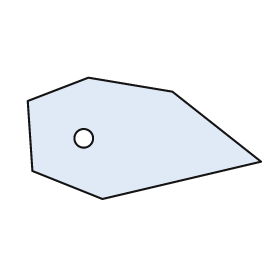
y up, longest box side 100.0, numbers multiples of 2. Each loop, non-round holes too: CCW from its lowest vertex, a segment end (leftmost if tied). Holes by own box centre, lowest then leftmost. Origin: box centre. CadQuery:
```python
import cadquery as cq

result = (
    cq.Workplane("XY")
    .moveTo(-18.0, -26.0)
    .lineTo(50.0, -10.0)
    .lineTo(12.0, 20.0)
    .lineTo(-24.0, 26.0)
    .lineTo(-50.0, 16.0)
    .lineTo(-48.0, -14.0)
    .close()
    .moveTo(-26.0, 0.0)
    .circle(4.0)
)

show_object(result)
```